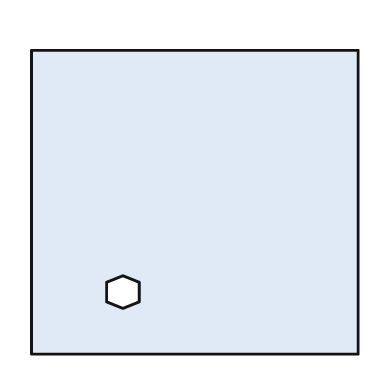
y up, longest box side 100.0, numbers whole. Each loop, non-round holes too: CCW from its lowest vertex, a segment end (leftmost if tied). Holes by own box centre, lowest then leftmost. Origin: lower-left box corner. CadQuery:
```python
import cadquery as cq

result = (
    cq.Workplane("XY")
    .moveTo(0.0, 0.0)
    .lineTo(100.0, 0.0)
    .lineTo(100.0, 93.0)
    .lineTo(0.0, 93.0)
    .close()
    .moveTo(28.0, 14.0)
    .lineTo(33.0, 16.0)
    .lineTo(33.0, 22.0)
    .lineTo(28.0, 24.0)
    .lineTo(23.0, 22.0)
    .lineTo(23.0, 16.0)
    .close()
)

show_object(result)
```